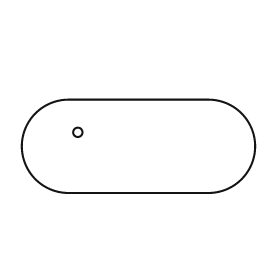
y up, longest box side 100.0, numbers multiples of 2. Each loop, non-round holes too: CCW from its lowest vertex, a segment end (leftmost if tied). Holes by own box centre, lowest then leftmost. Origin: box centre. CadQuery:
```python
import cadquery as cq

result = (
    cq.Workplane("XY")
    .moveTo(-30.0, -20.0)
    .lineTo(30.0, -20.0)
    .threePointArc((50.0, 0.0), (30.0, 20.0))
    .lineTo(-30.0, 20.0)
    .threePointArc((-50.0, 0.0), (-30.0, -20.0))
    .close()
    .moveTo(-26.0, 6.0)
    .circle(2.0)
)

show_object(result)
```